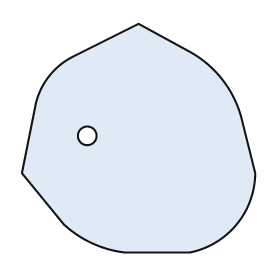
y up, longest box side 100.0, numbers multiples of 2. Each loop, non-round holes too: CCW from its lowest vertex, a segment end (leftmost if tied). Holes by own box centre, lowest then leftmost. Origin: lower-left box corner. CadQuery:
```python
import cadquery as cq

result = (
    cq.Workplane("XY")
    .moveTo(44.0, 0.0)
    .lineTo(72.0, 0.0)
    .threePointArc((92.0, 12.0), (100.0, 34.0))
    .lineTo(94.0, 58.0)
    .threePointArc((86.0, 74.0), (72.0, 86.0))
    .lineTo(50.0, 98.0)
    .lineTo(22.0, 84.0)
    .threePointArc((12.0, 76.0), (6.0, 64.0))
    .lineTo(0.0, 34.0)
    .lineTo(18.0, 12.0)
    .threePointArc((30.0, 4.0), (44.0, 0.0))
    .close()
    .moveTo(28.0, 50.0)
    .circle(4.0)
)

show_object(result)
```